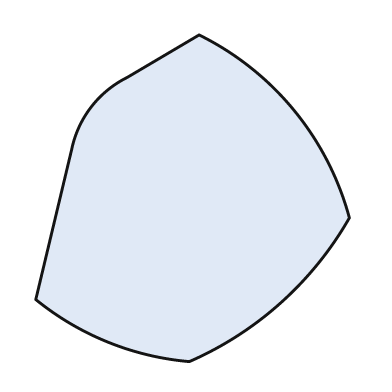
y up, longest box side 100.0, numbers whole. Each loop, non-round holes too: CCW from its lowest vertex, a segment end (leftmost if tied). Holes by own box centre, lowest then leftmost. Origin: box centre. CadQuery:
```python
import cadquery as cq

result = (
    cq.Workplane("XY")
    .moveTo(-1.0, -50.0)
    .threePointArc((27.0, -32.0), (48.0, -6.0))
    .threePointArc((31.0, 27.0), (2.0, 50.0))
    .lineTo(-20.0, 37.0)
    .threePointArc((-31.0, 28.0), (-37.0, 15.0))
    .lineTo(-48.0, -31.0)
    .threePointArc((-26.0, -44.0), (-1.0, -50.0))
    .close()
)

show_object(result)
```